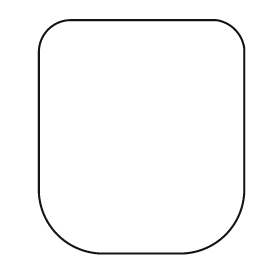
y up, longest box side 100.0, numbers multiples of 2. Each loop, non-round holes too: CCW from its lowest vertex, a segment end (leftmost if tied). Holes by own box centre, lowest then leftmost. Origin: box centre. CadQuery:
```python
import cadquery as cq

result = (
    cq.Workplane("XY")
    .moveTo(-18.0, -50.0)
    .lineTo(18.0, -50.0)
    .threePointArc((36.0, -42.0), (44.0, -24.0))
    .lineTo(44.0, 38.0)
    .threePointArc((40.0, 46.0), (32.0, 50.0))
    .lineTo(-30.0, 50.0)
    .threePointArc((-40.0, 46.0), (-44.0, 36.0))
    .lineTo(-44.0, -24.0)
    .threePointArc((-36.0, -42.0), (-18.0, -50.0))
    .close()
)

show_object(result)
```